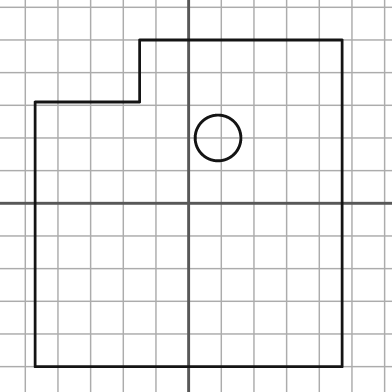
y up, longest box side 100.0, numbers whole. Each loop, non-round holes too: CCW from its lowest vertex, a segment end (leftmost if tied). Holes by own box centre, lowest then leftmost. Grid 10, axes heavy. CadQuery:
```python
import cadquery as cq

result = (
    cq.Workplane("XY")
    .moveTo(-47.0, -50.0)
    .lineTo(47.0, -50.0)
    .lineTo(47.0, 50.0)
    .lineTo(-15.0, 50.0)
    .lineTo(-15.0, 31.0)
    .lineTo(-47.0, 31.0)
    .close()
    .moveTo(9.0, 20.0)
    .circle(7.0)
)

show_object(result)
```